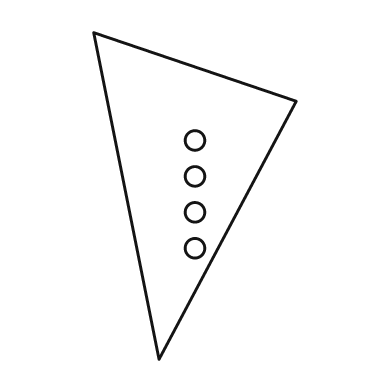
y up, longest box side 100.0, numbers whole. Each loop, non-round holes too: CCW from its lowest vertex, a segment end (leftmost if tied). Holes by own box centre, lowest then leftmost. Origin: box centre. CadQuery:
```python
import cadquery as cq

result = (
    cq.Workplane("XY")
    .moveTo(-11.0, -50.0)
    .lineTo(31.0, 29.0)
    .lineTo(-31.0, 50.0)
    .close()
    .moveTo(0.0, -16.0)
    .circle(3.0)
    .moveTo(0.0, -5.0)
    .circle(3.0)
    .moveTo(0.0, 6.0)
    .circle(3.0)
    .moveTo(0.0, 17.0)
    .circle(3.0)
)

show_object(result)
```